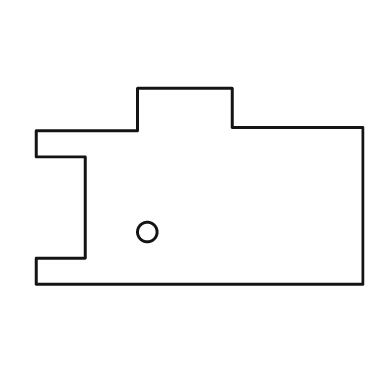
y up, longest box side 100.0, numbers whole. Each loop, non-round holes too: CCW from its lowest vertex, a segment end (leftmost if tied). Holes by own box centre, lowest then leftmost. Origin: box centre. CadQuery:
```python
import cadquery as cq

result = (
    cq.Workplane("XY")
    .moveTo(-50.0, -30.0)
    .lineTo(50.0, -30.0)
    .lineTo(50.0, 18.0)
    .lineTo(10.0, 18.0)
    .lineTo(10.0, 30.0)
    .lineTo(-19.0, 30.0)
    .lineTo(-19.0, 17.0)
    .lineTo(-50.0, 17.0)
    .lineTo(-50.0, 9.0)
    .lineTo(-35.0, 9.0)
    .lineTo(-35.0, -22.0)
    .lineTo(-50.0, -22.0)
    .close()
    .moveTo(-16.0, -14.0)
    .circle(3.0)
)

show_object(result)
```